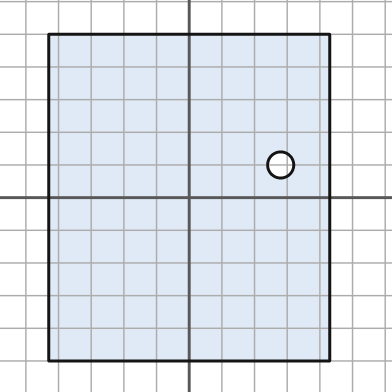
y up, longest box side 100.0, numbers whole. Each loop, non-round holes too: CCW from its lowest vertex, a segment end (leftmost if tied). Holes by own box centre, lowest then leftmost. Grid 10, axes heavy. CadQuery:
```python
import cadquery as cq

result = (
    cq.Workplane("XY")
    .moveTo(-43.0, -50.0)
    .lineTo(43.0, -50.0)
    .lineTo(43.0, 50.0)
    .lineTo(-43.0, 50.0)
    .close()
    .moveTo(28.0, 10.0)
    .circle(4.0)
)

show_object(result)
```